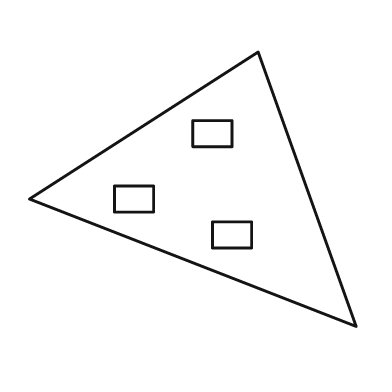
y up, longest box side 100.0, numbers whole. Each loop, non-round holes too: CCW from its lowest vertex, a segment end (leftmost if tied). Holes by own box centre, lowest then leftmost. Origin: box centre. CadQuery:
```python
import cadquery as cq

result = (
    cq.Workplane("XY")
    .moveTo(50.0, -42.0)
    .lineTo(20.0, 42.0)
    .lineTo(-50.0, -3.0)
    .close()
    .moveTo(6.0, -18.0)
    .lineTo(18.0, -18.0)
    .lineTo(18.0, -10.0)
    .lineTo(6.0, -10.0)
    .close()
    .moveTo(-24.0, -7.0)
    .lineTo(-12.0, -7.0)
    .lineTo(-12.0, 1.0)
    .lineTo(-24.0, 1.0)
    .close()
    .moveTo(0.0, 13.0)
    .lineTo(12.0, 13.0)
    .lineTo(12.0, 21.0)
    .lineTo(0.0, 21.0)
    .close()
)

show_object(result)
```